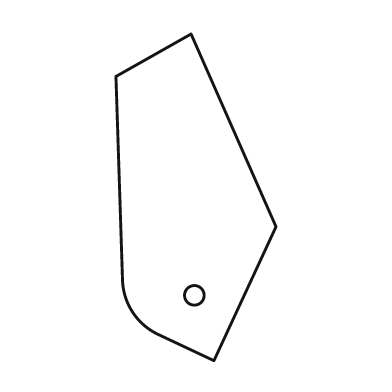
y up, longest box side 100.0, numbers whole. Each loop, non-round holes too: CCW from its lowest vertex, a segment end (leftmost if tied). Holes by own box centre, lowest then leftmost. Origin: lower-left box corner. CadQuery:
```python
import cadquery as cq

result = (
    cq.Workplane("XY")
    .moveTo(30.0, 0.0)
    .lineTo(49.0, 41.0)
    .lineTo(23.0, 100.0)
    .lineTo(0.0, 87.0)
    .lineTo(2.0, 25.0)
    .threePointArc((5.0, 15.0), (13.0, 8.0))
    .close()
    .moveTo(24.0, 20.0)
    .circle(3.0)
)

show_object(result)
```